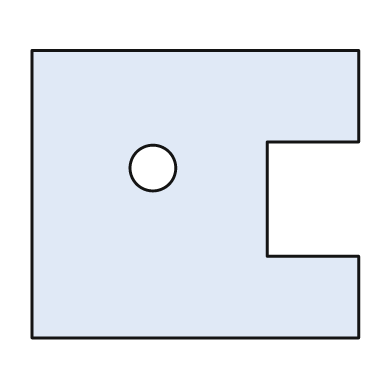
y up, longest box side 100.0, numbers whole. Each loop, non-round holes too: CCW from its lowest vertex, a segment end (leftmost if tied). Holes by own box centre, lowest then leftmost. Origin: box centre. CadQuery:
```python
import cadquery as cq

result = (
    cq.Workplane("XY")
    .moveTo(-50.0, -44.0)
    .lineTo(50.0, -44.0)
    .lineTo(50.0, -19.0)
    .lineTo(22.0, -19.0)
    .lineTo(22.0, 16.0)
    .lineTo(50.0, 16.0)
    .lineTo(50.0, 44.0)
    .lineTo(-50.0, 44.0)
    .close()
    .moveTo(-13.0, 8.0)
    .circle(7.0)
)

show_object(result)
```